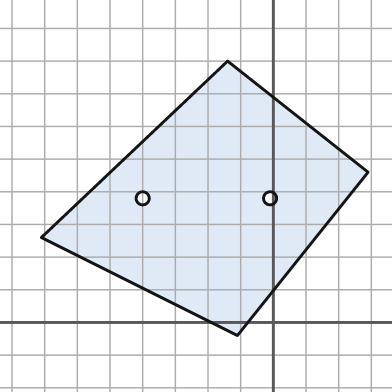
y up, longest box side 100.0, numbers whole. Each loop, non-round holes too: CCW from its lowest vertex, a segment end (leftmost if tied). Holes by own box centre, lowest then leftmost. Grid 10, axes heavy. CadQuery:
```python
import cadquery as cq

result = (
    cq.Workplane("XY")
    .moveTo(-11.0, -4.0)
    .lineTo(29.0, 46.0)
    .lineTo(-14.0, 80.0)
    .lineTo(-71.0, 26.0)
    .close()
    .moveTo(-40.0, 38.0)
    .circle(2.0)
    .moveTo(-1.0, 38.0)
    .circle(2.0)
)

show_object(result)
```